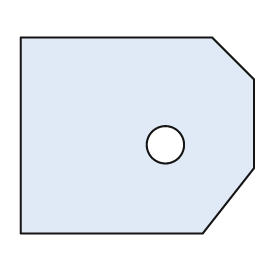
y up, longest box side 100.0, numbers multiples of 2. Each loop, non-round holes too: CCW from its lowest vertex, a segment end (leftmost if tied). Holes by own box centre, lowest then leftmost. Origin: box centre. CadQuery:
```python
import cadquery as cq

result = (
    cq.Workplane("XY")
    .moveTo(-50.0, -42.0)
    .lineTo(28.0, -42.0)
    .lineTo(50.0, -14.0)
    .lineTo(50.0, 24.0)
    .lineTo(32.0, 42.0)
    .lineTo(-50.0, 42.0)
    .close()
    .moveTo(12.0, -4.0)
    .circle(8.0)
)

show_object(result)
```